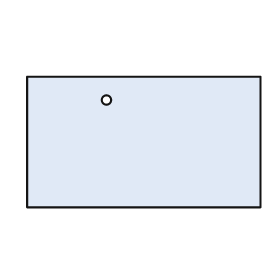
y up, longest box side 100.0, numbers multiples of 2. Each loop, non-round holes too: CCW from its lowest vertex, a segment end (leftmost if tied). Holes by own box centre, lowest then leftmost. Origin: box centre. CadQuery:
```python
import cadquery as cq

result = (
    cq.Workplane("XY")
    .moveTo(-50.0, -28.0)
    .lineTo(50.0, -28.0)
    .lineTo(50.0, 28.0)
    .lineTo(-50.0, 28.0)
    .close()
    .moveTo(-16.0, 18.0)
    .circle(2.0)
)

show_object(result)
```